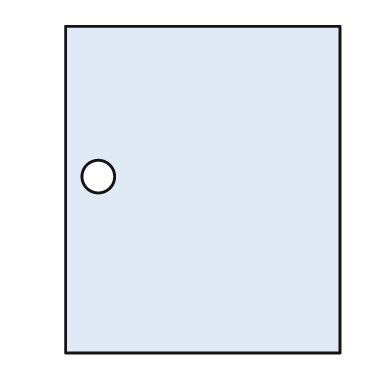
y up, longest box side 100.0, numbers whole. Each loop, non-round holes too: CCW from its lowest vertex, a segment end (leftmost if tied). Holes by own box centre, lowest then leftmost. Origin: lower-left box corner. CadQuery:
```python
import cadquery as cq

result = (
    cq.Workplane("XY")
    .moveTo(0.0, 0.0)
    .lineTo(84.0, 0.0)
    .lineTo(84.0, 100.0)
    .lineTo(0.0, 100.0)
    .close()
    .moveTo(10.0, 54.0)
    .circle(5.0)
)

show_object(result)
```